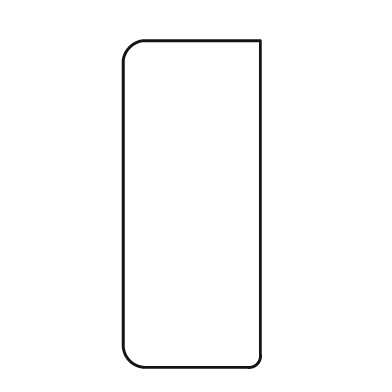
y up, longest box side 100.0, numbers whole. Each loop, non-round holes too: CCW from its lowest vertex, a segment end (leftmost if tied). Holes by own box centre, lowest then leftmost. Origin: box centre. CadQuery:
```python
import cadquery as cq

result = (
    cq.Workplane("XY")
    .moveTo(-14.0, -50.0)
    .lineTo(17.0, -50.0)
    .threePointArc((20.0, -49.0), (21.0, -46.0))
    .lineTo(21.0, 50.0)
    .lineTo(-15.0, 50.0)
    .threePointArc((-19.0, 48.0), (-21.0, 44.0))
    .lineTo(-21.0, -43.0)
    .threePointArc((-19.0, -48.0), (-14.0, -50.0))
    .close()
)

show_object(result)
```